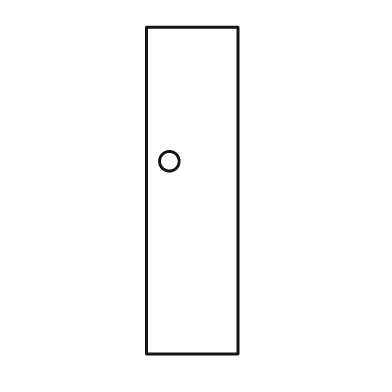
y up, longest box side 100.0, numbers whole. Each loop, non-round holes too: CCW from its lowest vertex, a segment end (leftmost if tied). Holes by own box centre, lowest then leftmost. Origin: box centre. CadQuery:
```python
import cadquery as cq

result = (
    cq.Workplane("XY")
    .moveTo(-14.0, -50.0)
    .lineTo(14.0, -50.0)
    .lineTo(14.0, 50.0)
    .lineTo(-14.0, 50.0)
    .close()
    .moveTo(-7.0, 9.0)
    .circle(3.0)
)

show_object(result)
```